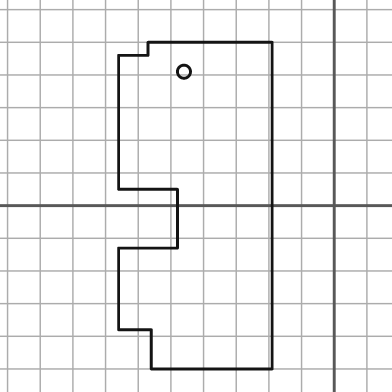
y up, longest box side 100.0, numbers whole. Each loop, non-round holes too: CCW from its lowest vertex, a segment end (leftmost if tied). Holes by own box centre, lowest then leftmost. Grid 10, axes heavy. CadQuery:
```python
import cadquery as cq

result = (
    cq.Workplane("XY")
    .moveTo(-56.0, -50.0)
    .lineTo(-19.0, -50.0)
    .lineTo(-19.0, 50.0)
    .lineTo(-57.0, 50.0)
    .lineTo(-57.0, 46.0)
    .lineTo(-66.0, 46.0)
    .lineTo(-66.0, 5.0)
    .lineTo(-48.0, 5.0)
    .lineTo(-48.0, -13.0)
    .lineTo(-66.0, -13.0)
    .lineTo(-66.0, -38.0)
    .lineTo(-56.0, -38.0)
    .close()
    .moveTo(-46.0, 41.0)
    .circle(2.0)
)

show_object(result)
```